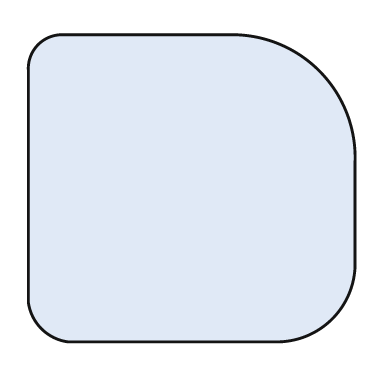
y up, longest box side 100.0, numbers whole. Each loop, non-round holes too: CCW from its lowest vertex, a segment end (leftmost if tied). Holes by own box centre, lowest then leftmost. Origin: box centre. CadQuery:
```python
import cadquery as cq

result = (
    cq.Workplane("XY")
    .moveTo(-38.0, -47.0)
    .lineTo(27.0, -47.0)
    .threePointArc((43.0, -40.0), (50.0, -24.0))
    .lineTo(50.0, 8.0)
    .threePointArc((39.0, 36.0), (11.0, 47.0))
    .lineTo(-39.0, 47.0)
    .threePointArc((-47.0, 44.0), (-50.0, 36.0))
    .lineTo(-50.0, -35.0)
    .threePointArc((-46.0, -43.0), (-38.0, -47.0))
    .close()
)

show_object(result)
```